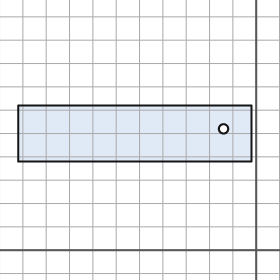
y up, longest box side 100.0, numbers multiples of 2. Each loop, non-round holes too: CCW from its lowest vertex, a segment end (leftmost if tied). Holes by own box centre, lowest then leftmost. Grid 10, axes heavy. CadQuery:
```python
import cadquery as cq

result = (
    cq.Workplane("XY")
    .moveTo(-102.0, 38.0)
    .lineTo(-2.0, 38.0)
    .lineTo(-2.0, 62.0)
    .lineTo(-102.0, 62.0)
    .close()
    .moveTo(-14.0, 52.0)
    .circle(2.0)
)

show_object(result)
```